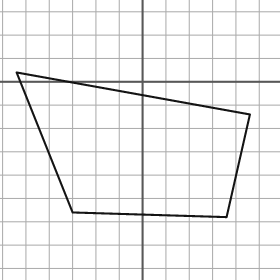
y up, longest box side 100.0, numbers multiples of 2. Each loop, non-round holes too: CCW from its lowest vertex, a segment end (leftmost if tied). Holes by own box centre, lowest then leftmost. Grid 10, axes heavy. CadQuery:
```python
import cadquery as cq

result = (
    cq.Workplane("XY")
    .moveTo(36.0, -58.0)
    .lineTo(46.0, -14.0)
    .lineTo(-54.0, 4.0)
    .lineTo(-30.0, -56.0)
    .close()
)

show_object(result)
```